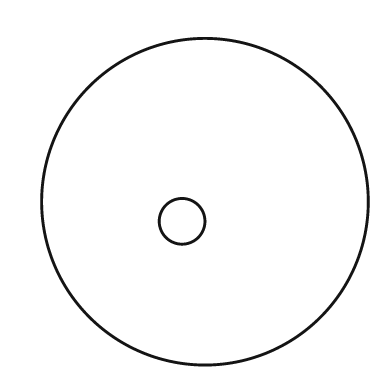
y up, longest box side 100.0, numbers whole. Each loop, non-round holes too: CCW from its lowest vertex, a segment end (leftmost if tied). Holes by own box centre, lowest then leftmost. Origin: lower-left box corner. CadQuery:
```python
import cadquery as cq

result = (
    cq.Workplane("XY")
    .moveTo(50.0, 50.0)
    .circle(50.0)
    .moveTo(43.0, 44.0)
    .circle(7.0)
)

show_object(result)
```